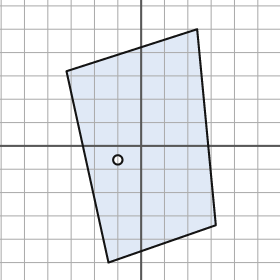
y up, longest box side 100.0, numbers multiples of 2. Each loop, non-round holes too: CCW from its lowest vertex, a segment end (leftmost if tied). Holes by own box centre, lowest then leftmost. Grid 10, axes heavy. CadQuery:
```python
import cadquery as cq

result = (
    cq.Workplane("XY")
    .moveTo(-14.0, -50.0)
    .lineTo(32.0, -34.0)
    .lineTo(24.0, 50.0)
    .lineTo(-32.0, 32.0)
    .close()
    .moveTo(-10.0, -6.0)
    .circle(2.0)
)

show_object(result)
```